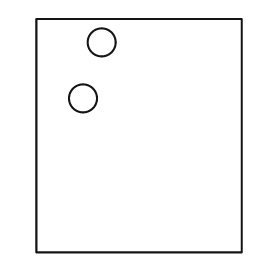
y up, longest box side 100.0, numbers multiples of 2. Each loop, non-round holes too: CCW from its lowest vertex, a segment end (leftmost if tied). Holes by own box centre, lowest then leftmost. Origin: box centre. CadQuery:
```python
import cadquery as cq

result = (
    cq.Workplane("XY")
    .moveTo(-44.0, -50.0)
    .lineTo(44.0, -50.0)
    .lineTo(44.0, 50.0)
    .lineTo(-44.0, 50.0)
    .close()
    .moveTo(-24.0, 16.0)
    .circle(6.0)
    .moveTo(-16.0, 40.0)
    .circle(6.0)
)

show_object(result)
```